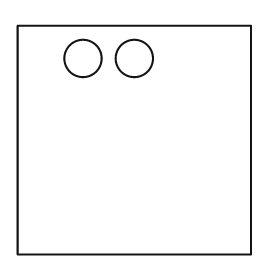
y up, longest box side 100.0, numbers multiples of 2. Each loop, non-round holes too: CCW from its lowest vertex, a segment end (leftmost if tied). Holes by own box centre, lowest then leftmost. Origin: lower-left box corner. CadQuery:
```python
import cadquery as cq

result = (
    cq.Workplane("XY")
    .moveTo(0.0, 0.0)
    .lineTo(100.0, 0.0)
    .lineTo(100.0, 98.0)
    .lineTo(0.0, 98.0)
    .close()
    .moveTo(28.0, 84.0)
    .circle(8.0)
    .moveTo(50.0, 84.0)
    .circle(8.0)
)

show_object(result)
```